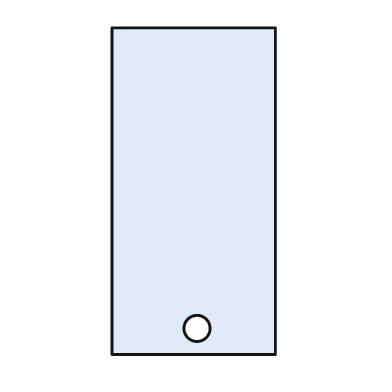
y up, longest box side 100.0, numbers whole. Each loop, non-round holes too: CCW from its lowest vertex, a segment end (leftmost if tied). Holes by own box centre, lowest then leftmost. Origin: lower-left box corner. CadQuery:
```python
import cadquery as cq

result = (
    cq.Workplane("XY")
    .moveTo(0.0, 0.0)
    .lineTo(50.0, 0.0)
    .lineTo(50.0, 100.0)
    .lineTo(0.0, 100.0)
    .close()
    .moveTo(26.0, 8.0)
    .circle(4.0)
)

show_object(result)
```